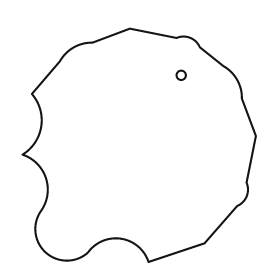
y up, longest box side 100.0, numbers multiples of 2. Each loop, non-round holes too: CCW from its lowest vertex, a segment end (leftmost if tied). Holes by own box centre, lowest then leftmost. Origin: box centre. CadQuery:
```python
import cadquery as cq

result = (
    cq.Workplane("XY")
    .moveTo(4.0, -50.0)
    .lineTo(28.0, -42.0)
    .lineTo(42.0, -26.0)
    .threePointArc((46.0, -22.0), (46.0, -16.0))
    .lineTo(50.0, 4.0)
    .lineTo(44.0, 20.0)
    .threePointArc((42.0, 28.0), (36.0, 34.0))
    .lineTo(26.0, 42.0)
    .threePointArc((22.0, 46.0), (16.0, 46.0))
    .lineTo(-4.0, 50.0)
    .lineTo(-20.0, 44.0)
    .threePointArc((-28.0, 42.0), (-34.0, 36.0))
    .lineTo(-46.0, 22.0)
    .threePointArc((-42.0, 8.0), (-50.0, -4.0))
    .threePointArc((-40.0, -14.0), (-42.0, -28.0))
    .threePointArc((-40.0, -46.0), (-22.0, -46.0))
    .threePointArc((-8.0, -40.0), (4.0, -50.0))
    .close()
    .moveTo(18.0, 30.0)
    .circle(2.0)
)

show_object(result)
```